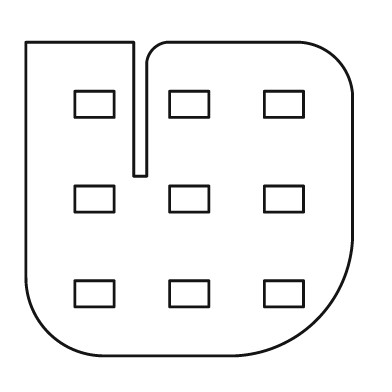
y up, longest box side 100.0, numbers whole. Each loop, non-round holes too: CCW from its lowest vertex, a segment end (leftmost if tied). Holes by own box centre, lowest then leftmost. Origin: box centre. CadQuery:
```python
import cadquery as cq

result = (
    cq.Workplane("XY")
    .moveTo(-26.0, -48.0)
    .lineTo(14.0, -48.0)
    .threePointArc((39.0, -37.0), (50.0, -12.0))
    .lineTo(50.0, 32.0)
    .threePointArc((45.0, 43.0), (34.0, 48.0))
    .lineTo(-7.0, 48.0)
    .threePointArc((-11.0, 46.0), (-13.0, 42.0))
    .lineTo(-13.0, 7.0)
    .lineTo(-17.0, 7.0)
    .lineTo(-17.0, 48.0)
    .lineTo(-50.0, 48.0)
    .lineTo(-50.0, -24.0)
    .threePointArc((-43.0, -41.0), (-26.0, -48.0))
    .close()
    .moveTo(-35.0, -33.0)
    .lineTo(-23.0, -33.0)
    .lineTo(-23.0, -25.0)
    .lineTo(-35.0, -25.0)
    .close()
    .moveTo(-6.0, -33.0)
    .lineTo(6.0, -33.0)
    .lineTo(6.0, -25.0)
    .lineTo(-6.0, -25.0)
    .close()
    .moveTo(23.0, -33.0)
    .lineTo(35.0, -33.0)
    .lineTo(35.0, -25.0)
    .lineTo(23.0, -25.0)
    .close()
    .moveTo(-35.0, -4.0)
    .lineTo(-23.0, -4.0)
    .lineTo(-23.0, 4.0)
    .lineTo(-35.0, 4.0)
    .close()
    .moveTo(-6.0, -4.0)
    .lineTo(6.0, -4.0)
    .lineTo(6.0, 4.0)
    .lineTo(-6.0, 4.0)
    .close()
    .moveTo(23.0, -4.0)
    .lineTo(35.0, -4.0)
    .lineTo(35.0, 4.0)
    .lineTo(23.0, 4.0)
    .close()
    .moveTo(-35.0, 25.0)
    .lineTo(-23.0, 25.0)
    .lineTo(-23.0, 33.0)
    .lineTo(-35.0, 33.0)
    .close()
    .moveTo(-6.0, 25.0)
    .lineTo(6.0, 25.0)
    .lineTo(6.0, 33.0)
    .lineTo(-6.0, 33.0)
    .close()
    .moveTo(23.0, 25.0)
    .lineTo(35.0, 25.0)
    .lineTo(35.0, 33.0)
    .lineTo(23.0, 33.0)
    .close()
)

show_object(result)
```